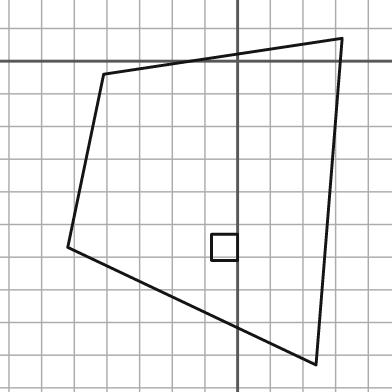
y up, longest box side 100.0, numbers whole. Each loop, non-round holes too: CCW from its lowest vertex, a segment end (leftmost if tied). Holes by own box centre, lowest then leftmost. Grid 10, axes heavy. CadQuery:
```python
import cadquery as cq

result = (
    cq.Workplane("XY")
    .moveTo(24.0, -93.0)
    .lineTo(32.0, 7.0)
    .lineTo(-41.0, -4.0)
    .lineTo(-52.0, -57.0)
    .close()
    .moveTo(-8.0, -61.0)
    .lineTo(0.0, -61.0)
    .lineTo(0.0, -53.0)
    .lineTo(-8.0, -53.0)
    .close()
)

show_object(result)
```